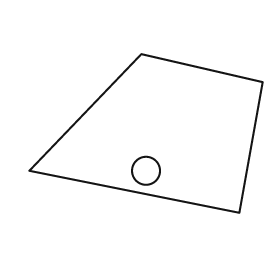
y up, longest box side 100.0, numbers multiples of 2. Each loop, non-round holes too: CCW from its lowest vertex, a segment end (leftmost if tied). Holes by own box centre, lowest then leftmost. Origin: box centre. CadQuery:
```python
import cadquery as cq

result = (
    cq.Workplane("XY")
    .moveTo(40.0, -34.0)
    .lineTo(50.0, 22.0)
    .lineTo(-2.0, 34.0)
    .lineTo(-50.0, -16.0)
    .close()
    .moveTo(0.0, -16.0)
    .circle(6.0)
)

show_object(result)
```